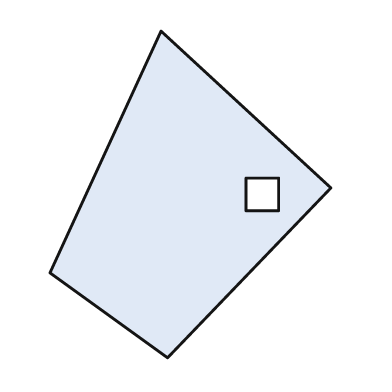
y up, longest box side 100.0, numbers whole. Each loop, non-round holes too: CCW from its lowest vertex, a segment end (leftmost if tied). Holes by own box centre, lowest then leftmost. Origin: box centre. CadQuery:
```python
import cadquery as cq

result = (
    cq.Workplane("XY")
    .moveTo(-7.0, -50.0)
    .lineTo(43.0, 2.0)
    .lineTo(-9.0, 50.0)
    .lineTo(-43.0, -24.0)
    .close()
    .moveTo(17.0, -5.0)
    .lineTo(27.0, -5.0)
    .lineTo(27.0, 5.0)
    .lineTo(17.0, 5.0)
    .close()
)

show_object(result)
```